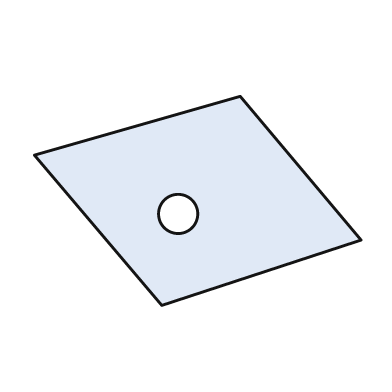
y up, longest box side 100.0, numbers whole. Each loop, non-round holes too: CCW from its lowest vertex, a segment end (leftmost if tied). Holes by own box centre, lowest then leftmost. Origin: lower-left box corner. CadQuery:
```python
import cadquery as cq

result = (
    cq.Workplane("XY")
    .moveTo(39.0, 0.0)
    .lineTo(100.0, 20.0)
    .lineTo(63.0, 64.0)
    .lineTo(0.0, 46.0)
    .close()
    .moveTo(44.0, 28.0)
    .circle(6.0)
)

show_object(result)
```